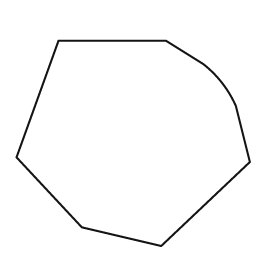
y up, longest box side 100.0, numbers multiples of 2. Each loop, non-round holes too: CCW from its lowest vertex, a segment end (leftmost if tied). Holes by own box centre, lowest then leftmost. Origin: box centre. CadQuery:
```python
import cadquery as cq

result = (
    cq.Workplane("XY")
    .moveTo(12.0, -44.0)
    .lineTo(50.0, -8.0)
    .lineTo(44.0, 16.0)
    .threePointArc((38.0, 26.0), (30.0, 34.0))
    .lineTo(14.0, 44.0)
    .lineTo(-32.0, 44.0)
    .lineTo(-50.0, -6.0)
    .lineTo(-22.0, -36.0)
    .close()
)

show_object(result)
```